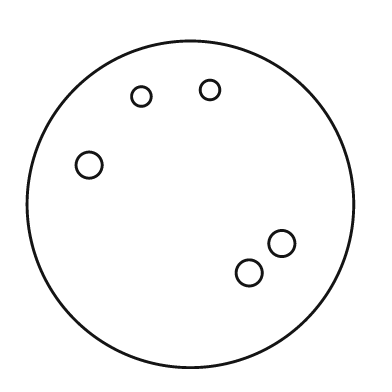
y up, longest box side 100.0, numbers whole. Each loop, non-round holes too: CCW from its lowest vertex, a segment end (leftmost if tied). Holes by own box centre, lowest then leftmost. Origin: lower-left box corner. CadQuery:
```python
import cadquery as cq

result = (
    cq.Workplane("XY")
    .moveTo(50.0, 50.0)
    .circle(50.0)
    .moveTo(68.0, 29.0)
    .circle(4.0)
    .moveTo(78.0, 38.0)
    .circle(4.0)
    .moveTo(19.0, 62.0)
    .circle(4.0)
    .moveTo(35.0, 83.0)
    .circle(3.0)
    .moveTo(56.0, 85.0)
    .circle(3.0)
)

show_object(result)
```